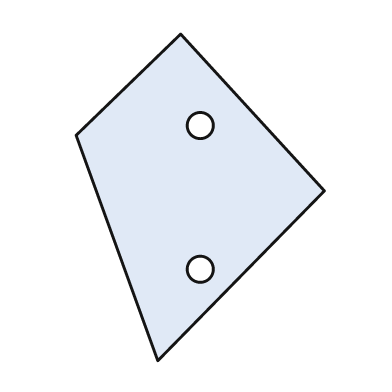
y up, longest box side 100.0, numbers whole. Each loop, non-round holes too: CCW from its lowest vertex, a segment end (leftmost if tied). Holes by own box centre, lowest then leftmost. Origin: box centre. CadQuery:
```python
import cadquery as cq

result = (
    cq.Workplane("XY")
    .moveTo(-13.0, -50.0)
    .lineTo(38.0, 2.0)
    .lineTo(-6.0, 50.0)
    .lineTo(-38.0, 19.0)
    .close()
    .moveTo(0.0, -22.0)
    .circle(4.0)
    .moveTo(0.0, 22.0)
    .circle(4.0)
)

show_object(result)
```